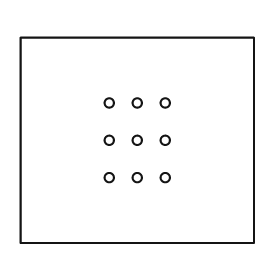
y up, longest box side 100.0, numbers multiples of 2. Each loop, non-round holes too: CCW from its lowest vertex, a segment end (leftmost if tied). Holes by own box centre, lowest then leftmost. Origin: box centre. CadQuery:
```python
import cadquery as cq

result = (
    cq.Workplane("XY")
    .moveTo(-50.0, -44.0)
    .lineTo(50.0, -44.0)
    .lineTo(50.0, 44.0)
    .lineTo(-50.0, 44.0)
    .close()
    .moveTo(-12.0, -16.0)
    .circle(2.0)
    .moveTo(0.0, -16.0)
    .circle(2.0)
    .moveTo(12.0, -16.0)
    .circle(2.0)
    .moveTo(-12.0, 0.0)
    .circle(2.0)
    .moveTo(0.0, 0.0)
    .circle(2.0)
    .moveTo(12.0, 0.0)
    .circle(2.0)
    .moveTo(-12.0, 16.0)
    .circle(2.0)
    .moveTo(0.0, 16.0)
    .circle(2.0)
    .moveTo(12.0, 16.0)
    .circle(2.0)
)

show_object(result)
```